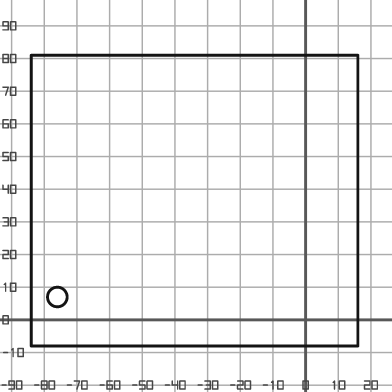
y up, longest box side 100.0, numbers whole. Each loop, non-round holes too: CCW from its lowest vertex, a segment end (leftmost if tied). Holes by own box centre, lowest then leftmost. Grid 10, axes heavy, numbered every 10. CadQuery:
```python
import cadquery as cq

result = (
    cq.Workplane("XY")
    .moveTo(-84.0, -8.0)
    .lineTo(16.0, -8.0)
    .lineTo(16.0, 81.0)
    .lineTo(-84.0, 81.0)
    .close()
    .moveTo(-76.0, 7.0)
    .circle(3.0)
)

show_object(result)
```